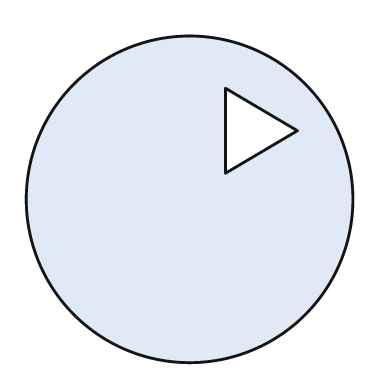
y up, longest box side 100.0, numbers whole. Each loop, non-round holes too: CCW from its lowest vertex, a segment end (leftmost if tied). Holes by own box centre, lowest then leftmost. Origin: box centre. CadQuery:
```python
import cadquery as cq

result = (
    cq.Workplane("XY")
    .moveTo(0.0, 0.0)
    .circle(50.0)
    .moveTo(11.0, 8.0)
    .lineTo(33.0, 21.0)
    .lineTo(11.0, 34.0)
    .close()
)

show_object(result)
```